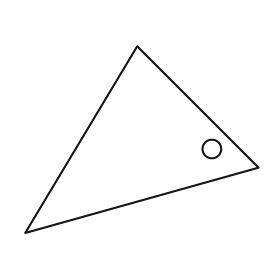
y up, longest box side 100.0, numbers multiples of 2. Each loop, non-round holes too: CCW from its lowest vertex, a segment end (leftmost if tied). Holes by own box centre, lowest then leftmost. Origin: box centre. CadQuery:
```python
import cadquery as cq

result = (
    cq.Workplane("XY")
    .moveTo(-50.0, -40.0)
    .lineTo(50.0, -12.0)
    .lineTo(-2.0, 40.0)
    .close()
    .moveTo(30.0, -4.0)
    .circle(4.0)
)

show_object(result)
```